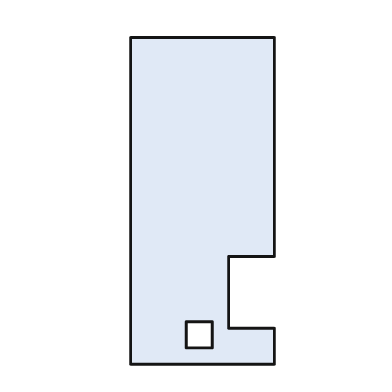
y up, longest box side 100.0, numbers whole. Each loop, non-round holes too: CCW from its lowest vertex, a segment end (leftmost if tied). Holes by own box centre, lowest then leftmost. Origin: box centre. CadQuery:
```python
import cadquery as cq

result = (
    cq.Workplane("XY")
    .moveTo(-22.0, -50.0)
    .lineTo(22.0, -50.0)
    .lineTo(22.0, -39.0)
    .lineTo(8.0, -39.0)
    .lineTo(8.0, -17.0)
    .lineTo(22.0, -17.0)
    .lineTo(22.0, 50.0)
    .lineTo(-22.0, 50.0)
    .close()
    .moveTo(-5.0, -45.0)
    .lineTo(3.0, -45.0)
    .lineTo(3.0, -37.0)
    .lineTo(-5.0, -37.0)
    .close()
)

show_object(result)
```